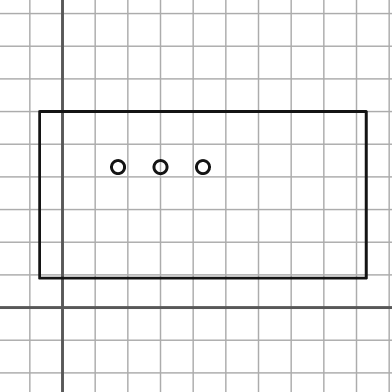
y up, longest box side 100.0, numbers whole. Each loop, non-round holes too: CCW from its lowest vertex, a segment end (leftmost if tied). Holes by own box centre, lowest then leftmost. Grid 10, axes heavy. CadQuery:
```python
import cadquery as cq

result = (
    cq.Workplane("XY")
    .moveTo(-7.0, 9.0)
    .lineTo(93.0, 9.0)
    .lineTo(93.0, 60.0)
    .lineTo(-7.0, 60.0)
    .close()
    .moveTo(17.0, 43.0)
    .circle(2.0)
    .moveTo(30.0, 43.0)
    .circle(2.0)
    .moveTo(43.0, 43.0)
    .circle(2.0)
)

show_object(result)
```